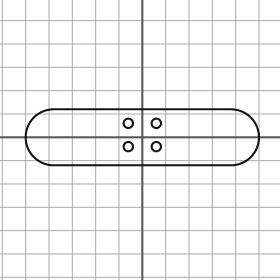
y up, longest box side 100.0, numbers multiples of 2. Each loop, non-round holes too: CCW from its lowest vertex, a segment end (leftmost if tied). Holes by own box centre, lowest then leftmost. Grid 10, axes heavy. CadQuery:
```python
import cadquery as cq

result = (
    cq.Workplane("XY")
    .moveTo(-38.0, -12.0)
    .lineTo(38.0, -12.0)
    .threePointArc((50.0, 0.0), (38.0, 12.0))
    .lineTo(-38.0, 12.0)
    .threePointArc((-50.0, 0.0), (-38.0, -12.0))
    .close()
    .moveTo(-6.0, -4.0)
    .circle(2.0)
    .moveTo(6.0, -4.0)
    .circle(2.0)
    .moveTo(-6.0, 6.0)
    .circle(2.0)
    .moveTo(6.0, 6.0)
    .circle(2.0)
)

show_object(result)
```